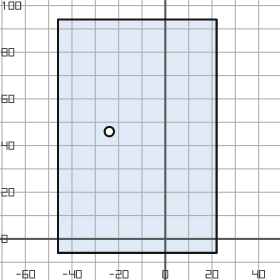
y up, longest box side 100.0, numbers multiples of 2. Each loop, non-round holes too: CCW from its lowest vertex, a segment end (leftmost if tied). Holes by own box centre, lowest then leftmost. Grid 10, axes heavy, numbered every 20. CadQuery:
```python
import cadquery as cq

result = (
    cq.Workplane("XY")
    .moveTo(-46.0, -6.0)
    .lineTo(22.0, -6.0)
    .lineTo(22.0, 94.0)
    .lineTo(-46.0, 94.0)
    .close()
    .moveTo(-24.0, 46.0)
    .circle(2.0)
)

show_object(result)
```